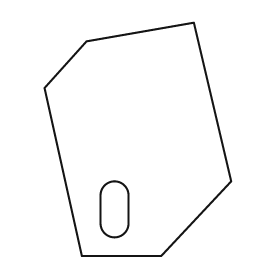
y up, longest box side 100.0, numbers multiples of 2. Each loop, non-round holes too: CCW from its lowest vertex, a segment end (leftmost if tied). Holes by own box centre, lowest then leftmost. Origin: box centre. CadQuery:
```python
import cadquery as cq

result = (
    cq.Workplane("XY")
    .moveTo(-24.0, -50.0)
    .lineTo(10.0, -50.0)
    .lineTo(40.0, -18.0)
    .lineTo(24.0, 50.0)
    .lineTo(-22.0, 42.0)
    .lineTo(-40.0, 22.0)
    .close()
    .moveTo(-16.0, -36.0)
    .threePointArc((-10.0, -42.0), (-4.0, -36.0))
    .lineTo(-4.0, -24.0)
    .threePointArc((-10.0, -18.0), (-16.0, -24.0))
    .close()
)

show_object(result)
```